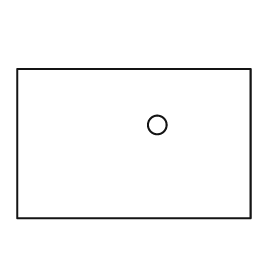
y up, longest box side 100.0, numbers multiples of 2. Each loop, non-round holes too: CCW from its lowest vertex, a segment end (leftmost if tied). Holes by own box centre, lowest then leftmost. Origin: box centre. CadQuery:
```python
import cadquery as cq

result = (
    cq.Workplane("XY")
    .moveTo(-50.0, -32.0)
    .lineTo(50.0, -32.0)
    .lineTo(50.0, 32.0)
    .lineTo(-50.0, 32.0)
    .close()
    .moveTo(10.0, 8.0)
    .circle(4.0)
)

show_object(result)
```